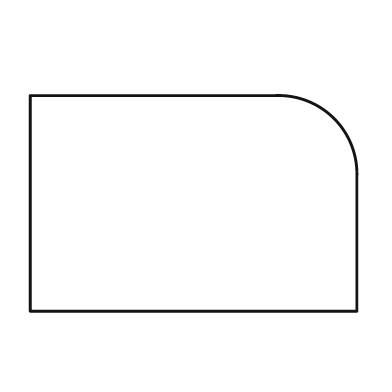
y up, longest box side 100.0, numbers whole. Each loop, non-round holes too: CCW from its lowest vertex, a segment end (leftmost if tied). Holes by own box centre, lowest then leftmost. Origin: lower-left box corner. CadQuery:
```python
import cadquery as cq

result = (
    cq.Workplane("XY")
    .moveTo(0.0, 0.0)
    .lineTo(100.0, 0.0)
    .lineTo(100.0, 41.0)
    .threePointArc((93.0, 59.0), (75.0, 66.0))
    .lineTo(0.0, 66.0)
    .close()
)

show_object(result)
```